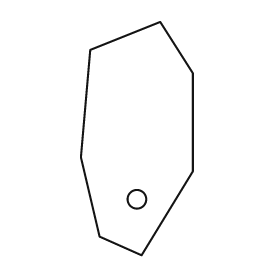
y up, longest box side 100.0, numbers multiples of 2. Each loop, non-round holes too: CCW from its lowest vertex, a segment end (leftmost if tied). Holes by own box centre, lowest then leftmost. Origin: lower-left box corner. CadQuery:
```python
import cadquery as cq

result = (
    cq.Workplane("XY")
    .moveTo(26.0, 0.0)
    .lineTo(48.0, 36.0)
    .lineTo(48.0, 78.0)
    .lineTo(34.0, 100.0)
    .lineTo(4.0, 88.0)
    .lineTo(0.0, 42.0)
    .lineTo(8.0, 8.0)
    .close()
    .moveTo(24.0, 24.0)
    .circle(4.0)
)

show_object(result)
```